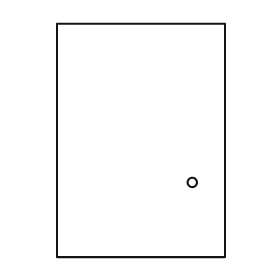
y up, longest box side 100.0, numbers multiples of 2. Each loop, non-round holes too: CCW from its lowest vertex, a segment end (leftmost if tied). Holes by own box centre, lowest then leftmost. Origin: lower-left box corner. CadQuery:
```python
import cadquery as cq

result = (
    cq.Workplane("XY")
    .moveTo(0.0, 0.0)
    .lineTo(72.0, 0.0)
    .lineTo(72.0, 100.0)
    .lineTo(0.0, 100.0)
    .close()
    .moveTo(58.0, 32.0)
    .circle(2.0)
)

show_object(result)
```